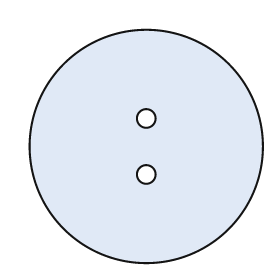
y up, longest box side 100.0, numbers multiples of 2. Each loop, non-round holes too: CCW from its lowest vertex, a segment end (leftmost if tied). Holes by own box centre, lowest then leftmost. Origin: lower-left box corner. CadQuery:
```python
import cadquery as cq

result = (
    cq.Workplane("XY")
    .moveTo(50.0, 50.0)
    .circle(50.0)
    .moveTo(50.0, 38.0)
    .circle(4.0)
    .moveTo(50.0, 62.0)
    .circle(4.0)
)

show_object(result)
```